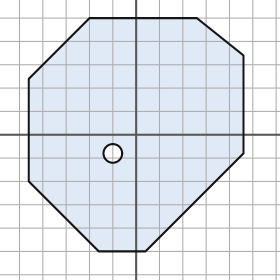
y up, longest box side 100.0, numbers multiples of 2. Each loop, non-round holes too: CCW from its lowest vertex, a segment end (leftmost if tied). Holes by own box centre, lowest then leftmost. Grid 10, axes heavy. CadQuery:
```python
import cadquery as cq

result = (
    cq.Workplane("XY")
    .moveTo(-16.0, -50.0)
    .lineTo(4.0, -50.0)
    .lineTo(46.0, -8.0)
    .lineTo(46.0, 34.0)
    .lineTo(26.0, 50.0)
    .lineTo(-20.0, 50.0)
    .lineTo(-46.0, 24.0)
    .lineTo(-46.0, -20.0)
    .close()
    .moveTo(-10.0, -8.0)
    .circle(4.0)
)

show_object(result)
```